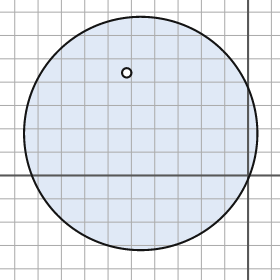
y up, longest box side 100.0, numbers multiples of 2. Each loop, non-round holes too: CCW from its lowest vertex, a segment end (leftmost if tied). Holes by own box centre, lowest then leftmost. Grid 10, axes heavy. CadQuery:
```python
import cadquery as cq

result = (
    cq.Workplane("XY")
    .moveTo(-46.0, 18.0)
    .circle(50.0)
    .moveTo(-52.0, 44.0)
    .circle(2.0)
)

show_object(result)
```